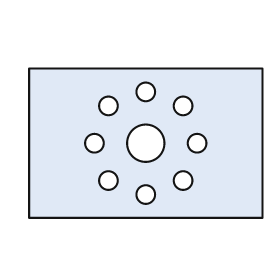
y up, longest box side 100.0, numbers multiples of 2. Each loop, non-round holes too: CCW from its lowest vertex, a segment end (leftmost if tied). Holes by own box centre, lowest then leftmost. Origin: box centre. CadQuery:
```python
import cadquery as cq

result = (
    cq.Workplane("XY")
    .moveTo(-50.0, -32.0)
    .lineTo(50.0, -32.0)
    .lineTo(50.0, 32.0)
    .lineTo(-50.0, 32.0)
    .close()
    .moveTo(0.0, -22.0)
    .circle(4.0)
    .moveTo(-16.0, -16.0)
    .circle(4.0)
    .moveTo(16.0, -16.0)
    .circle(4.0)
    .moveTo(-22.0, 0.0)
    .circle(4.0)
    .moveTo(0.0, 0.0)
    .circle(8.0)
    .moveTo(22.0, 0.0)
    .circle(4.0)
    .moveTo(-16.0, 16.0)
    .circle(4.0)
    .moveTo(16.0, 16.0)
    .circle(4.0)
    .moveTo(0.0, 22.0)
    .circle(4.0)
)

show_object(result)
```